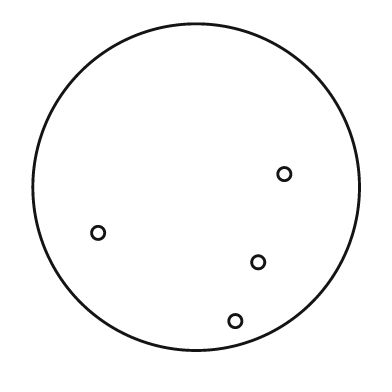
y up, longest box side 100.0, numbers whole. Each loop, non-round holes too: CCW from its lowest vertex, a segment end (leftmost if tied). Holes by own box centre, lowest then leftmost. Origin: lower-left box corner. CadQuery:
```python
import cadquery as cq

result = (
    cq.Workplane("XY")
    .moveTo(50.0, 50.0)
    .circle(50.0)
    .moveTo(62.0, 9.0)
    .circle(2.0)
    .moveTo(69.0, 27.0)
    .circle(2.0)
    .moveTo(20.0, 36.0)
    .circle(2.0)
    .moveTo(77.0, 54.0)
    .circle(2.0)
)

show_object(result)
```